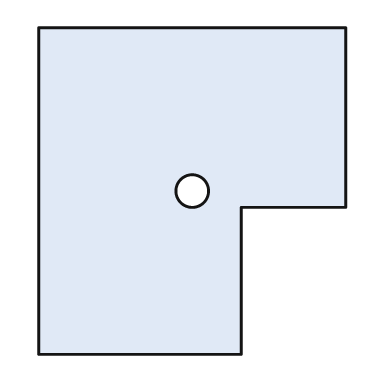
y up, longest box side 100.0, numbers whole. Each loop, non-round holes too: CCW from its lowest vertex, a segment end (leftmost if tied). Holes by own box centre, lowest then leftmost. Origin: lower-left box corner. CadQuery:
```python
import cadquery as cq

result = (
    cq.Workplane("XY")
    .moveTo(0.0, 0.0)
    .lineTo(62.0, 0.0)
    .lineTo(62.0, 45.0)
    .lineTo(94.0, 45.0)
    .lineTo(94.0, 100.0)
    .lineTo(0.0, 100.0)
    .close()
    .moveTo(47.0, 50.0)
    .circle(5.0)
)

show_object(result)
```